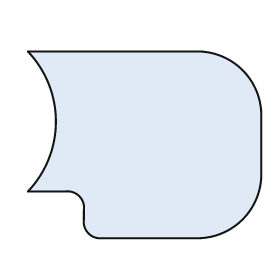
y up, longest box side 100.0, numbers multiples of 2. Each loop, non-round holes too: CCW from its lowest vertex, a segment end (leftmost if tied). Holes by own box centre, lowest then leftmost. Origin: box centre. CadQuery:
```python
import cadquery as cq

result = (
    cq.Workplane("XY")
    .moveTo(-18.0, -40.0)
    .lineTo(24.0, -40.0)
    .threePointArc((42.0, -32.0), (50.0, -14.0))
    .lineTo(50.0, 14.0)
    .threePointArc((42.0, 32.0), (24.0, 40.0))
    .lineTo(-50.0, 40.0)
    .threePointArc((-38.0, 10.0), (-50.0, -20.0))
    .lineTo(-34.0, -20.0)
    .threePointArc((-28.0, -22.0), (-26.0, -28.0))
    .lineTo(-26.0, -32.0)
    .threePointArc((-24.0, -38.0), (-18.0, -40.0))
    .close()
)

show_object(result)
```